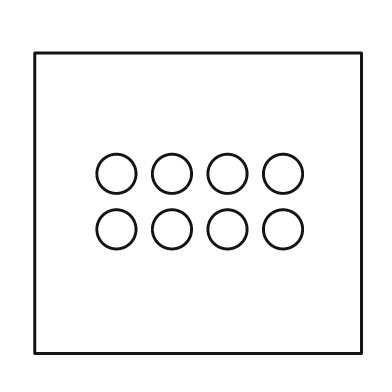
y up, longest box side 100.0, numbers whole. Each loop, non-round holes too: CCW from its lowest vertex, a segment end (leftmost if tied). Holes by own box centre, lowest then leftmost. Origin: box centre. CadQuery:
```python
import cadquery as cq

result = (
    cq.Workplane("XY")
    .moveTo(-50.0, -46.0)
    .lineTo(50.0, -46.0)
    .lineTo(50.0, 46.0)
    .lineTo(-50.0, 46.0)
    .close()
    .moveTo(-25.0, -8.0)
    .circle(6.0)
    .moveTo(-8.0, -8.0)
    .circle(6.0)
    .moveTo(9.0, -8.0)
    .circle(6.0)
    .moveTo(26.0, -8.0)
    .circle(6.0)
    .moveTo(-25.0, 9.0)
    .circle(6.0)
    .moveTo(-8.0, 9.0)
    .circle(6.0)
    .moveTo(9.0, 9.0)
    .circle(6.0)
    .moveTo(26.0, 9.0)
    .circle(6.0)
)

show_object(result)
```